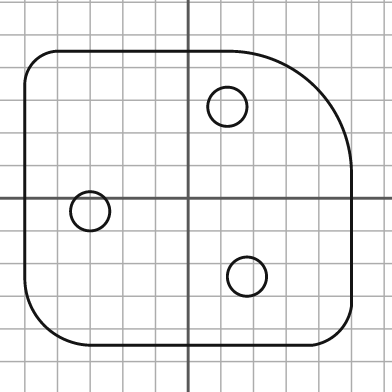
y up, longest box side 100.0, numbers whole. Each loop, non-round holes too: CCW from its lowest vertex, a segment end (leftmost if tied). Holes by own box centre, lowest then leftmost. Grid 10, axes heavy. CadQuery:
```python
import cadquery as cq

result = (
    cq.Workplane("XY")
    .moveTo(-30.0, -45.0)
    .lineTo(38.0, -45.0)
    .threePointArc((46.0, -41.0), (50.0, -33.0))
    .lineTo(50.0, 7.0)
    .threePointArc((39.0, 34.0), (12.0, 45.0))
    .lineTo(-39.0, 45.0)
    .threePointArc((-47.0, 42.0), (-50.0, 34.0))
    .lineTo(-50.0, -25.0)
    .threePointArc((-44.0, -39.0), (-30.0, -45.0))
    .close()
    .moveTo(18.0, -24.0)
    .circle(6.0)
    .moveTo(-30.0, -4.0)
    .circle(6.0)
    .moveTo(12.0, 28.0)
    .circle(6.0)
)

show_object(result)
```